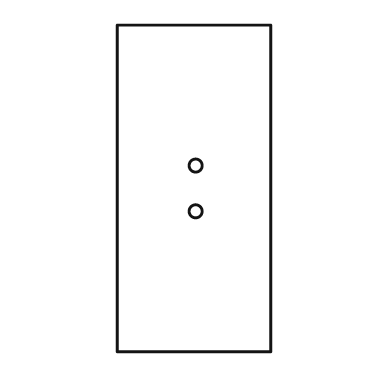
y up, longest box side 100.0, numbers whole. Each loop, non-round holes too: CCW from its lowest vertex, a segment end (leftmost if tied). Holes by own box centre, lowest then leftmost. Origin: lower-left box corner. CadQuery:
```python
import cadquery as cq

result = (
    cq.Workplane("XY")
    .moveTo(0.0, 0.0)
    .lineTo(47.0, 0.0)
    .lineTo(47.0, 100.0)
    .lineTo(0.0, 100.0)
    .close()
    .moveTo(24.0, 43.0)
    .circle(2.0)
    .moveTo(24.0, 57.0)
    .circle(2.0)
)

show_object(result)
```